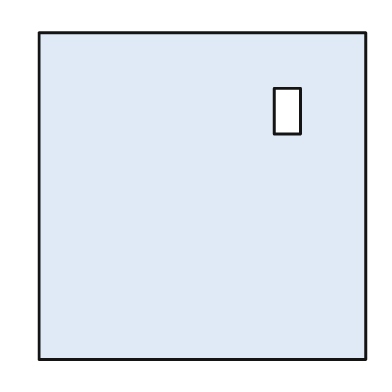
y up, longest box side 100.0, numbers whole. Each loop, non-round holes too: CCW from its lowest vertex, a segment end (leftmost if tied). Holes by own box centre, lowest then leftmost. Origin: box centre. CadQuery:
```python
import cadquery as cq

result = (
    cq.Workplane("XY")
    .moveTo(-50.0, -50.0)
    .lineTo(50.0, -50.0)
    .lineTo(50.0, 50.0)
    .lineTo(-50.0, 50.0)
    .close()
    .moveTo(22.0, 19.0)
    .lineTo(30.0, 19.0)
    .lineTo(30.0, 33.0)
    .lineTo(22.0, 33.0)
    .close()
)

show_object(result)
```